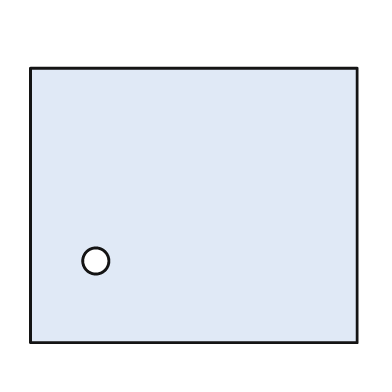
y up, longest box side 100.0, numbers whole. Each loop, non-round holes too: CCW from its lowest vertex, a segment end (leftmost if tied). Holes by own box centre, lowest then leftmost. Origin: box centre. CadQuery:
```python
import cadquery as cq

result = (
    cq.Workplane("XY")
    .moveTo(-50.0, -42.0)
    .lineTo(50.0, -42.0)
    .lineTo(50.0, 42.0)
    .lineTo(-50.0, 42.0)
    .close()
    .moveTo(-30.0, -17.0)
    .circle(4.0)
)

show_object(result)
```